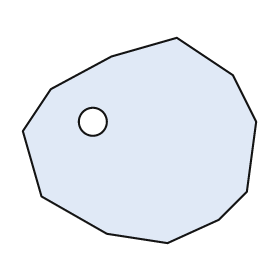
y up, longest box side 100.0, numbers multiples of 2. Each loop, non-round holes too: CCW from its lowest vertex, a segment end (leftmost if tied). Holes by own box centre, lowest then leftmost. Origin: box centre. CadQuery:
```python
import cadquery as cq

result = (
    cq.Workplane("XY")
    .moveTo(12.0, -44.0)
    .lineTo(34.0, -34.0)
    .lineTo(46.0, -22.0)
    .lineTo(50.0, 8.0)
    .lineTo(40.0, 28.0)
    .lineTo(16.0, 44.0)
    .lineTo(-12.0, 36.0)
    .lineTo(-38.0, 22.0)
    .lineTo(-50.0, 4.0)
    .lineTo(-42.0, -24.0)
    .lineTo(-14.0, -40.0)
    .close()
    .moveTo(-20.0, 8.0)
    .circle(6.0)
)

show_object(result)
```